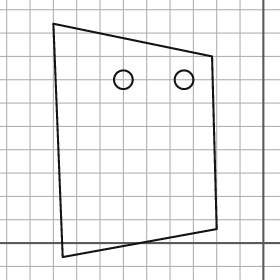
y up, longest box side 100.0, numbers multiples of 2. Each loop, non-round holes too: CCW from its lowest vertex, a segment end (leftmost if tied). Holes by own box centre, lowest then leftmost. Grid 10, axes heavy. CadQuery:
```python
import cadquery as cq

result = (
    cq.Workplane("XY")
    .moveTo(-86.0, -6.0)
    .lineTo(-20.0, 6.0)
    .lineTo(-22.0, 80.0)
    .lineTo(-90.0, 94.0)
    .close()
    .moveTo(-60.0, 70.0)
    .circle(4.0)
    .moveTo(-34.0, 70.0)
    .circle(4.0)
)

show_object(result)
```